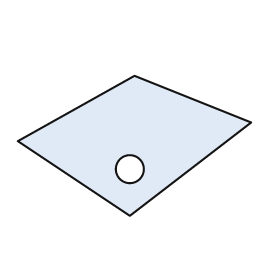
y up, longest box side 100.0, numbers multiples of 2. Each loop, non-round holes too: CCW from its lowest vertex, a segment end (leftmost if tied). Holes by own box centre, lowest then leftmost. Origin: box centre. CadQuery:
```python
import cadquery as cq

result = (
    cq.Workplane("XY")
    .moveTo(-2.0, -30.0)
    .lineTo(50.0, 10.0)
    .lineTo(0.0, 30.0)
    .lineTo(-50.0, 2.0)
    .close()
    .moveTo(-2.0, -10.0)
    .circle(6.0)
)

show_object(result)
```